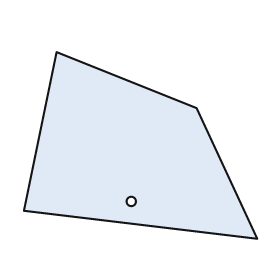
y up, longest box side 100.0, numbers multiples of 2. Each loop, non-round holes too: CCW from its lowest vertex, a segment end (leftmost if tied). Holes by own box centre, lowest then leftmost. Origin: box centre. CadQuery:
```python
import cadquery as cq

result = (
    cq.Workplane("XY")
    .moveTo(50.0, -40.0)
    .lineTo(24.0, 16.0)
    .lineTo(-36.0, 40.0)
    .lineTo(-50.0, -28.0)
    .close()
    .moveTo(-4.0, -24.0)
    .circle(2.0)
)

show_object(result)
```